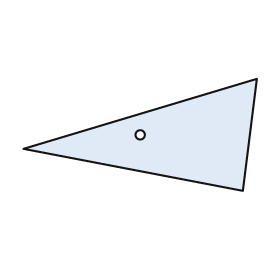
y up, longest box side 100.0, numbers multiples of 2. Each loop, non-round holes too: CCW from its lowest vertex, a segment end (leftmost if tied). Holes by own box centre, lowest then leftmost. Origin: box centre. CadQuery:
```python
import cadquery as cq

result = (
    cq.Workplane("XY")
    .moveTo(44.0, -24.0)
    .lineTo(50.0, 24.0)
    .lineTo(-50.0, -6.0)
    .close()
    .moveTo(0.0, 0.0)
    .circle(2.0)
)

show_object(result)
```